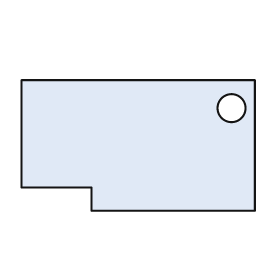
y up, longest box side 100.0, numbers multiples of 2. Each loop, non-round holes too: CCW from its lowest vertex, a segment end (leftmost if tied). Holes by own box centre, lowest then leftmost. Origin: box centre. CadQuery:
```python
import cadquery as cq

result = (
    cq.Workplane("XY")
    .moveTo(-20.0, -28.0)
    .lineTo(50.0, -28.0)
    .lineTo(50.0, 28.0)
    .lineTo(-50.0, 28.0)
    .lineTo(-50.0, -18.0)
    .lineTo(-20.0, -18.0)
    .close()
    .moveTo(40.0, 16.0)
    .circle(6.0)
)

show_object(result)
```